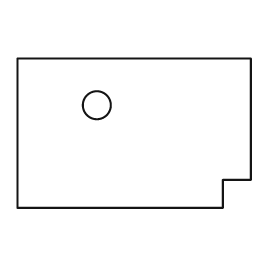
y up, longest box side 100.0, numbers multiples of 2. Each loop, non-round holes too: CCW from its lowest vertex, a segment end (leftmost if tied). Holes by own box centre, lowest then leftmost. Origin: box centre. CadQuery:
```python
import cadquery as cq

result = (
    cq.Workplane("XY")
    .moveTo(-50.0, -32.0)
    .lineTo(38.0, -32.0)
    .lineTo(38.0, -20.0)
    .lineTo(50.0, -20.0)
    .lineTo(50.0, 32.0)
    .lineTo(-50.0, 32.0)
    .close()
    .moveTo(-16.0, 12.0)
    .circle(6.0)
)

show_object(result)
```